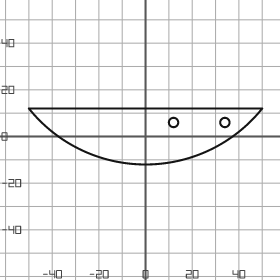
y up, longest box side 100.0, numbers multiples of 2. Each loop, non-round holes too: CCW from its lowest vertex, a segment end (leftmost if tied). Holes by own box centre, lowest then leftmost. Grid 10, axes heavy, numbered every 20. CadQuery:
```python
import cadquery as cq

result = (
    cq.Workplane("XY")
    .moveTo(-50.0, 12.0)
    .threePointArc((0.0, -12.0), (50.0, 12.0))
    .close()
    .moveTo(12.0, 6.0)
    .circle(2.0)
    .moveTo(34.0, 6.0)
    .circle(2.0)
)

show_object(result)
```